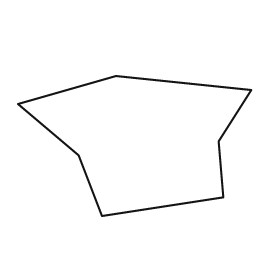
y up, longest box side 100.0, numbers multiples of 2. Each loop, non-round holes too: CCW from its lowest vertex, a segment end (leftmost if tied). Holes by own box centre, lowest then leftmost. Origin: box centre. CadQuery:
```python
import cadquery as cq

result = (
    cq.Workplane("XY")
    .moveTo(-14.0, -30.0)
    .lineTo(38.0, -22.0)
    .lineTo(36.0, 2.0)
    .lineTo(50.0, 24.0)
    .lineTo(-8.0, 30.0)
    .lineTo(-50.0, 18.0)
    .lineTo(-24.0, -4.0)
    .close()
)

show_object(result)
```